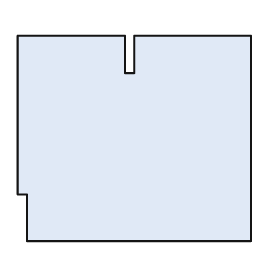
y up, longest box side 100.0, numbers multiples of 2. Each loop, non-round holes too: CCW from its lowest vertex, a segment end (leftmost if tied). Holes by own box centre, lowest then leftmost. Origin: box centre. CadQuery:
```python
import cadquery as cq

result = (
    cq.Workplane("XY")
    .moveTo(-46.0, -44.0)
    .lineTo(50.0, -44.0)
    .lineTo(50.0, 44.0)
    .lineTo(0.0, 44.0)
    .lineTo(0.0, 28.0)
    .lineTo(-4.0, 28.0)
    .lineTo(-4.0, 44.0)
    .lineTo(-50.0, 44.0)
    .lineTo(-50.0, -24.0)
    .lineTo(-46.0, -24.0)
    .close()
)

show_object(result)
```